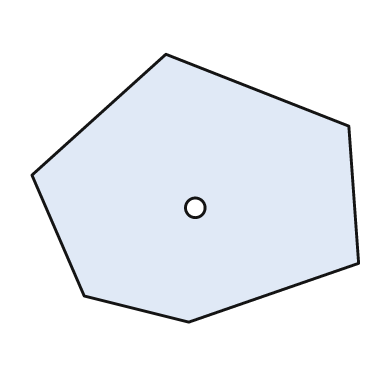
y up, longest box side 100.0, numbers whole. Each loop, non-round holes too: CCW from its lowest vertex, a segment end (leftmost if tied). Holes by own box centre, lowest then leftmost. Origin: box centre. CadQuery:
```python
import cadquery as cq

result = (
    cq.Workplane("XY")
    .moveTo(-2.0, -41.0)
    .lineTo(50.0, -23.0)
    .lineTo(47.0, 19.0)
    .lineTo(-9.0, 41.0)
    .lineTo(-50.0, 4.0)
    .lineTo(-34.0, -33.0)
    .close()
    .moveTo(0.0, -6.0)
    .circle(3.0)
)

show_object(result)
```